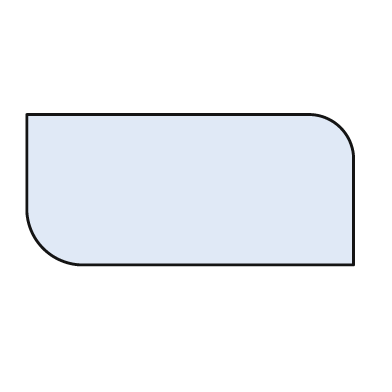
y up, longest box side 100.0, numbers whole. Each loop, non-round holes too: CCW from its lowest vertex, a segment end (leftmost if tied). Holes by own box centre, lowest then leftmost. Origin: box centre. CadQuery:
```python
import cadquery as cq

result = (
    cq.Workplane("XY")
    .moveTo(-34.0, -23.0)
    .lineTo(50.0, -23.0)
    .lineTo(50.0, 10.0)
    .threePointArc((46.0, 19.0), (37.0, 23.0))
    .lineTo(-50.0, 23.0)
    .lineTo(-50.0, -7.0)
    .threePointArc((-45.0, -18.0), (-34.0, -23.0))
    .close()
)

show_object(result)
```